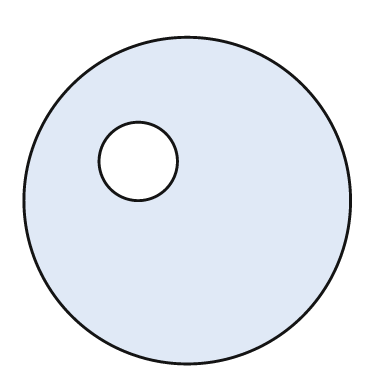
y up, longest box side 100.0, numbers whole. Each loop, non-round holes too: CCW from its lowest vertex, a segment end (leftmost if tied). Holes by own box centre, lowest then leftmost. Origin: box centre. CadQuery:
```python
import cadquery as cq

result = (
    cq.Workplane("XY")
    .moveTo(0.0, 0.0)
    .circle(50.0)
    .moveTo(-15.0, 12.0)
    .circle(12.0)
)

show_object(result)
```